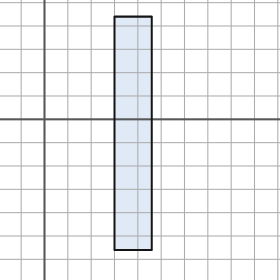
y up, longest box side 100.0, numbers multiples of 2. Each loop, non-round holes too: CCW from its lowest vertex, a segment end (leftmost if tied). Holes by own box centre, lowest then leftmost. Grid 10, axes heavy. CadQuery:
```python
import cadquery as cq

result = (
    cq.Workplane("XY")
    .moveTo(30.0, -56.0)
    .lineTo(46.0, -56.0)
    .lineTo(46.0, 44.0)
    .lineTo(30.0, 44.0)
    .close()
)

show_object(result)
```